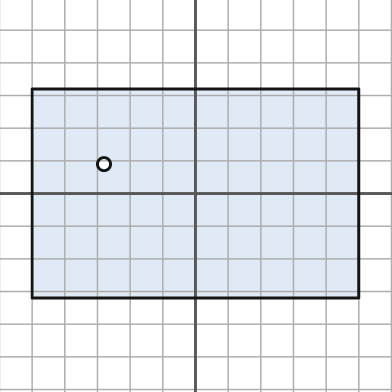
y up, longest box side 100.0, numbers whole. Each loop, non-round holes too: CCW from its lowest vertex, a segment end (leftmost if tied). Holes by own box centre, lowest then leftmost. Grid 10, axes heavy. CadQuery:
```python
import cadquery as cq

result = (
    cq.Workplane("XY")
    .moveTo(-50.0, -32.0)
    .lineTo(50.0, -32.0)
    .lineTo(50.0, 32.0)
    .lineTo(-50.0, 32.0)
    .close()
    .moveTo(-28.0, 9.0)
    .circle(2.0)
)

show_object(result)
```